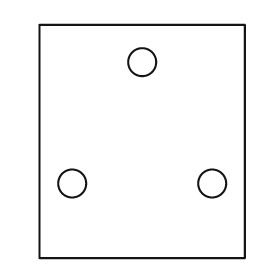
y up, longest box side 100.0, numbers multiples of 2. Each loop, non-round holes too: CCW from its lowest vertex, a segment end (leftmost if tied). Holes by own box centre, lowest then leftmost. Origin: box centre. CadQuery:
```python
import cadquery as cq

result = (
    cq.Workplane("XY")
    .moveTo(-44.0, -50.0)
    .lineTo(44.0, -50.0)
    .lineTo(44.0, 50.0)
    .lineTo(-44.0, 50.0)
    .close()
    .moveTo(-30.0, -18.0)
    .circle(6.0)
    .moveTo(30.0, -18.0)
    .circle(6.0)
    .moveTo(0.0, 34.0)
    .circle(6.0)
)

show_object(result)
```